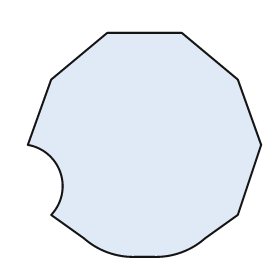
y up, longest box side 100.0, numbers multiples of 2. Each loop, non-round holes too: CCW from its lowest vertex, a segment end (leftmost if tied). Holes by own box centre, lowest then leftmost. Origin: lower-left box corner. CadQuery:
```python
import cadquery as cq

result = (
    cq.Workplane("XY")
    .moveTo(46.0, 0.0)
    .lineTo(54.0, 0.0)
    .threePointArc((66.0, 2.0), (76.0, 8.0))
    .lineTo(90.0, 18.0)
    .lineTo(100.0, 48.0)
    .lineTo(90.0, 76.0)
    .lineTo(66.0, 96.0)
    .lineTo(34.0, 96.0)
    .lineTo(10.0, 76.0)
    .lineTo(0.0, 48.0)
    .threePointArc((14.0, 36.0), (10.0, 18.0))
    .lineTo(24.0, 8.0)
    .threePointArc((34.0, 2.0), (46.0, 0.0))
    .close()
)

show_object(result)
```